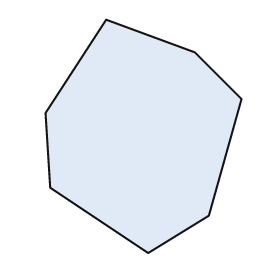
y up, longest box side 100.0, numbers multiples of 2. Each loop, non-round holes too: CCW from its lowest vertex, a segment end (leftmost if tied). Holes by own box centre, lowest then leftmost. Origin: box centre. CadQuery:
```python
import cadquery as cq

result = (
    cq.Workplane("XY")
    .moveTo(2.0, -50.0)
    .lineTo(28.0, -34.0)
    .lineTo(42.0, 16.0)
    .lineTo(22.0, 36.0)
    .lineTo(-16.0, 50.0)
    .lineTo(-42.0, 10.0)
    .lineTo(-40.0, -22.0)
    .close()
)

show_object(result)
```